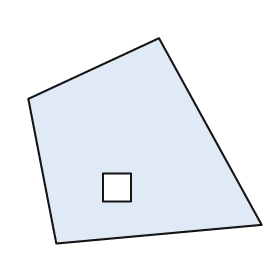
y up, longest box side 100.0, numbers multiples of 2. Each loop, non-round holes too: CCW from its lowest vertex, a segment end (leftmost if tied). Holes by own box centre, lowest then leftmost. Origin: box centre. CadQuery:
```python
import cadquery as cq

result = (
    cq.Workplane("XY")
    .moveTo(-38.0, -44.0)
    .lineTo(50.0, -36.0)
    .lineTo(6.0, 44.0)
    .lineTo(-50.0, 18.0)
    .close()
    .moveTo(-18.0, -26.0)
    .lineTo(-6.0, -26.0)
    .lineTo(-6.0, -14.0)
    .lineTo(-18.0, -14.0)
    .close()
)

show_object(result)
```